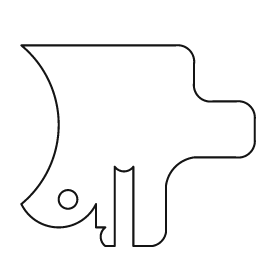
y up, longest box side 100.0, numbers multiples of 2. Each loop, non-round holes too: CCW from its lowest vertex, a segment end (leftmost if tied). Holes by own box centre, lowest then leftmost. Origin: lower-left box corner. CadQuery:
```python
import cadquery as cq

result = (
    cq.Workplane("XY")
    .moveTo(36.0, 0.0)
    .lineTo(40.0, 0.0)
    .lineTo(40.0, 34.0)
    .threePointArc((44.0, 32.0), (48.0, 34.0))
    .lineTo(48.0, 0.0)
    .lineTo(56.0, 0.0)
    .threePointArc((60.0, 2.0), (62.0, 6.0))
    .lineTo(62.0, 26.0)
    .threePointArc((66.0, 34.0), (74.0, 38.0))
    .lineTo(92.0, 38.0)
    .threePointArc((98.0, 40.0), (100.0, 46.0))
    .lineTo(100.0, 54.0)
    .threePointArc((98.0, 60.0), (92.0, 62.0))
    .lineTo(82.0, 62.0)
    .threePointArc((76.0, 64.0), (74.0, 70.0))
    .lineTo(74.0, 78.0)
    .threePointArc((72.0, 84.0), (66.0, 86.0))
    .lineTo(0.0, 86.0)
    .threePointArc((16.0, 52.0), (0.0, 18.0))
    .threePointArc((16.0, 8.0), (32.0, 18.0))
    .lineTo(32.0, 8.0)
    .lineTo(36.0, 8.0)
    .threePointArc((34.0, 4.0), (36.0, 0.0))
    .close()
    .moveTo(20.0, 20.0)
    .circle(4.0)
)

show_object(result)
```